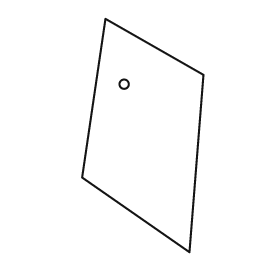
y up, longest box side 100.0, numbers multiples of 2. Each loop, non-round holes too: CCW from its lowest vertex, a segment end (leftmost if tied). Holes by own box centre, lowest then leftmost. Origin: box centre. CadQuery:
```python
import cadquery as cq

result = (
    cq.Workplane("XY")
    .moveTo(20.0, -50.0)
    .lineTo(26.0, 26.0)
    .lineTo(-16.0, 50.0)
    .lineTo(-26.0, -18.0)
    .close()
    .moveTo(-8.0, 22.0)
    .circle(2.0)
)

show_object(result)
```